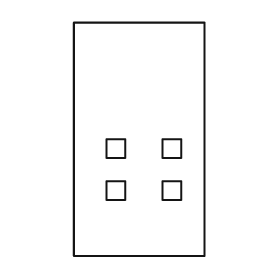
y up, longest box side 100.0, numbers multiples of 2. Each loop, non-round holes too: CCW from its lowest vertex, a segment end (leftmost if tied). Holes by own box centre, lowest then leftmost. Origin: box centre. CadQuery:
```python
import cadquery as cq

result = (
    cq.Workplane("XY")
    .moveTo(-28.0, -50.0)
    .lineTo(28.0, -50.0)
    .lineTo(28.0, 50.0)
    .lineTo(-28.0, 50.0)
    .close()
    .moveTo(-14.0, -26.0)
    .lineTo(-6.0, -26.0)
    .lineTo(-6.0, -18.0)
    .lineTo(-14.0, -18.0)
    .close()
    .moveTo(10.0, -26.0)
    .lineTo(18.0, -26.0)
    .lineTo(18.0, -18.0)
    .lineTo(10.0, -18.0)
    .close()
    .moveTo(-14.0, -8.0)
    .lineTo(-6.0, -8.0)
    .lineTo(-6.0, 0.0)
    .lineTo(-14.0, 0.0)
    .close()
    .moveTo(10.0, -8.0)
    .lineTo(18.0, -8.0)
    .lineTo(18.0, 0.0)
    .lineTo(10.0, 0.0)
    .close()
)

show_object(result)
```